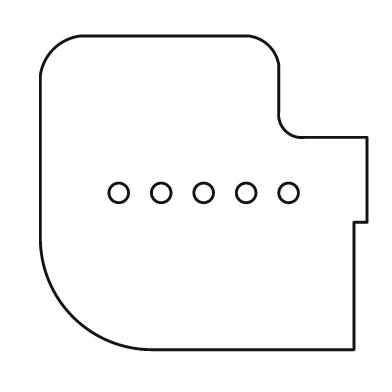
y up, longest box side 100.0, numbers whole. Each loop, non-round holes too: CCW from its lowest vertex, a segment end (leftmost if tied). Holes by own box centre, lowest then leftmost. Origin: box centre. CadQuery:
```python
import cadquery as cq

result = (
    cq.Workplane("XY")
    .moveTo(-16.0, -48.0)
    .lineTo(46.0, -48.0)
    .lineTo(46.0, -9.0)
    .lineTo(50.0, -9.0)
    .lineTo(50.0, 17.0)
    .lineTo(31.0, 17.0)
    .threePointArc((25.0, 19.0), (23.0, 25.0))
    .lineTo(23.0, 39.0)
    .threePointArc((20.0, 45.0), (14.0, 48.0))
    .lineTo(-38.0, 48.0)
    .threePointArc((-46.0, 44.0), (-50.0, 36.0))
    .lineTo(-50.0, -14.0)
    .threePointArc((-40.0, -38.0), (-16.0, -48.0))
    .close()
    .moveTo(-26.0, 0.0)
    .circle(3.0)
    .moveTo(-13.0, 0.0)
    .circle(3.0)
    .moveTo(0.0, 0.0)
    .circle(3.0)
    .moveTo(13.0, 0.0)
    .circle(3.0)
    .moveTo(26.0, 0.0)
    .circle(3.0)
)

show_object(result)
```